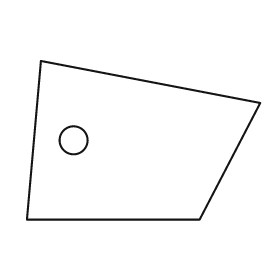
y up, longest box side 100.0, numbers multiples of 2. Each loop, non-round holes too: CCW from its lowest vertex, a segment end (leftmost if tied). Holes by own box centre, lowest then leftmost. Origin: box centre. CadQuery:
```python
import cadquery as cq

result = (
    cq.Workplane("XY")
    .moveTo(-50.0, -34.0)
    .lineTo(24.0, -34.0)
    .lineTo(50.0, 16.0)
    .lineTo(-44.0, 34.0)
    .close()
    .moveTo(-30.0, 0.0)
    .circle(6.0)
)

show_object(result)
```